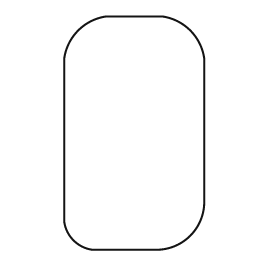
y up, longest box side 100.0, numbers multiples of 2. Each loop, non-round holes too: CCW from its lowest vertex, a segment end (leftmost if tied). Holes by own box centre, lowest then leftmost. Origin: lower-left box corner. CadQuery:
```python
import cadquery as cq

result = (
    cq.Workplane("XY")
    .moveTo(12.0, 0.0)
    .lineTo(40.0, 0.0)
    .threePointArc((54.0, 6.0), (60.0, 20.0))
    .lineTo(60.0, 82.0)
    .threePointArc((54.0, 94.0), (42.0, 100.0))
    .lineTo(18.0, 100.0)
    .threePointArc((6.0, 94.0), (0.0, 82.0))
    .lineTo(0.0, 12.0)
    .threePointArc((4.0, 4.0), (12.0, 0.0))
    .close()
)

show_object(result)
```